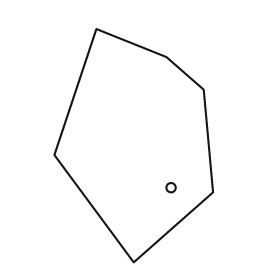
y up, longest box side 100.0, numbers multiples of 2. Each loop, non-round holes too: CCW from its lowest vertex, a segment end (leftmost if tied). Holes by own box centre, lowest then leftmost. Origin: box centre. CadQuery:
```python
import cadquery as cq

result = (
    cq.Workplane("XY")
    .moveTo(0.0, -50.0)
    .lineTo(34.0, -20.0)
    .lineTo(30.0, 24.0)
    .lineTo(14.0, 38.0)
    .lineTo(-16.0, 50.0)
    .lineTo(-34.0, -4.0)
    .close()
    .moveTo(16.0, -18.0)
    .circle(2.0)
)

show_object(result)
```